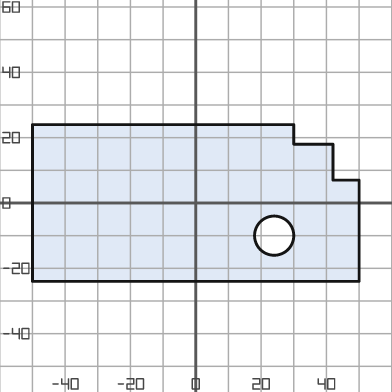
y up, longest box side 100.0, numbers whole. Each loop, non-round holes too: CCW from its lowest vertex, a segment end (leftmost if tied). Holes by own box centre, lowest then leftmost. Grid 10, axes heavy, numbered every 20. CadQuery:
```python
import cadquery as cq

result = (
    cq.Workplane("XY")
    .moveTo(-50.0, -24.0)
    .lineTo(50.0, -24.0)
    .lineTo(50.0, 7.0)
    .lineTo(42.0, 7.0)
    .lineTo(42.0, 18.0)
    .lineTo(30.0, 18.0)
    .lineTo(30.0, 24.0)
    .lineTo(-50.0, 24.0)
    .close()
    .moveTo(24.0, -10.0)
    .circle(6.0)
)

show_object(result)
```